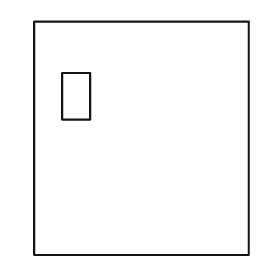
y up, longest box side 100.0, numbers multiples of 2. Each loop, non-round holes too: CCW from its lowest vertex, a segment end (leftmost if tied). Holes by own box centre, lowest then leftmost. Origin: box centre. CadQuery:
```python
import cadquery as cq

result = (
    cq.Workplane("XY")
    .moveTo(-46.0, -50.0)
    .lineTo(46.0, -50.0)
    .lineTo(46.0, 50.0)
    .lineTo(-46.0, 50.0)
    .close()
    .moveTo(-34.0, 8.0)
    .lineTo(-22.0, 8.0)
    .lineTo(-22.0, 28.0)
    .lineTo(-34.0, 28.0)
    .close()
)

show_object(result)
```